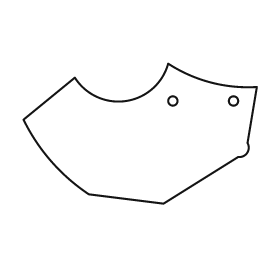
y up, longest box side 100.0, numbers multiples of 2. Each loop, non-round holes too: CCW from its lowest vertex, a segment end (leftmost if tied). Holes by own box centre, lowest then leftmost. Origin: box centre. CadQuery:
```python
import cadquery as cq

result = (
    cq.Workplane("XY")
    .moveTo(10.0, -30.0)
    .lineTo(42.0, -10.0)
    .threePointArc((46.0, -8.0), (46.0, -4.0))
    .lineTo(50.0, 20.0)
    .threePointArc((30.0, 22.0), (12.0, 30.0))
    .threePointArc((-6.0, 14.0), (-28.0, 24.0))
    .lineTo(-50.0, 6.0)
    .threePointArc((-38.0, -12.0), (-22.0, -26.0))
    .close()
    .moveTo(14.0, 14.0)
    .circle(2.0)
    .moveTo(40.0, 14.0)
    .circle(2.0)
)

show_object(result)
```